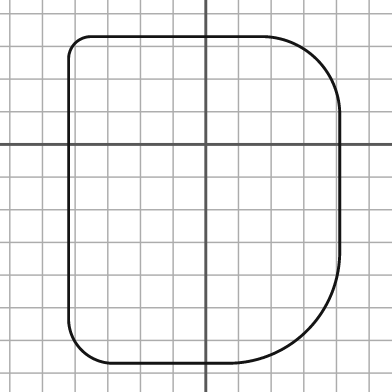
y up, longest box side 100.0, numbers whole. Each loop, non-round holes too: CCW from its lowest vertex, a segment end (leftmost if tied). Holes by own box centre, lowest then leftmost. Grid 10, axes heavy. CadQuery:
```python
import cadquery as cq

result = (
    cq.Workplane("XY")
    .moveTo(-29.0, -67.0)
    .lineTo(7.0, -67.0)
    .threePointArc((31.0, -57.0), (41.0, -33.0))
    .lineTo(41.0, 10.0)
    .threePointArc((34.0, 26.0), (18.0, 33.0))
    .lineTo(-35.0, 33.0)
    .threePointArc((-40.0, 31.0), (-42.0, 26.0))
    .lineTo(-42.0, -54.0)
    .threePointArc((-38.0, -63.0), (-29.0, -67.0))
    .close()
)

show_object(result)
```